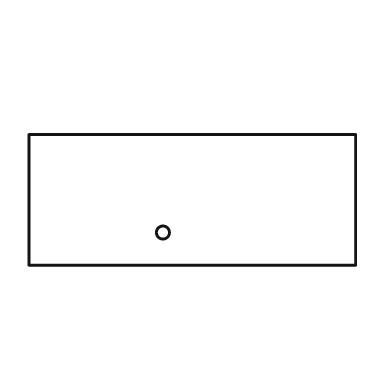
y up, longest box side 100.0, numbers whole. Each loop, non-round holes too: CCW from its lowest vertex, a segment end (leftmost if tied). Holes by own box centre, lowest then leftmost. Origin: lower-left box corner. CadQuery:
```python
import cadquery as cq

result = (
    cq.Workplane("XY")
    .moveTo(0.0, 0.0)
    .lineTo(100.0, 0.0)
    .lineTo(100.0, 40.0)
    .lineTo(0.0, 40.0)
    .close()
    .moveTo(41.0, 10.0)
    .circle(2.0)
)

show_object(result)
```